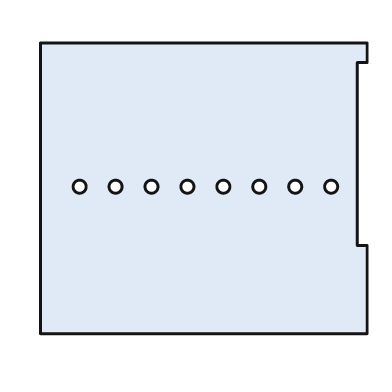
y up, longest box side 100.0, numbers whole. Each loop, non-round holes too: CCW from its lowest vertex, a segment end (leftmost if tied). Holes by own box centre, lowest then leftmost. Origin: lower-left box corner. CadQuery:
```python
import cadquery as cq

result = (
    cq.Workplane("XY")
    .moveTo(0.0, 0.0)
    .lineTo(100.0, 0.0)
    .lineTo(100.0, 27.0)
    .lineTo(97.0, 27.0)
    .lineTo(97.0, 83.0)
    .lineTo(100.0, 83.0)
    .lineTo(100.0, 89.0)
    .lineTo(0.0, 89.0)
    .close()
    .moveTo(12.0, 45.0)
    .circle(2.0)
    .moveTo(23.0, 45.0)
    .circle(2.0)
    .moveTo(34.0, 45.0)
    .circle(2.0)
    .moveTo(45.0, 45.0)
    .circle(2.0)
    .moveTo(56.0, 45.0)
    .circle(2.0)
    .moveTo(67.0, 45.0)
    .circle(2.0)
    .moveTo(78.0, 45.0)
    .circle(2.0)
    .moveTo(89.0, 45.0)
    .circle(2.0)
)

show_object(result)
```